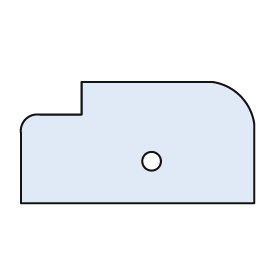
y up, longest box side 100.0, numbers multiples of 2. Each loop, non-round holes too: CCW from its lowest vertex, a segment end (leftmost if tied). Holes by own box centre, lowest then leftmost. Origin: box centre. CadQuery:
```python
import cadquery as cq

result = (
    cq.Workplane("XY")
    .moveTo(-50.0, -26.0)
    .lineTo(50.0, -26.0)
    .lineTo(50.0, 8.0)
    .threePointArc((44.0, 20.0), (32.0, 26.0))
    .lineTo(-24.0, 26.0)
    .lineTo(-24.0, 12.0)
    .lineTo(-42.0, 12.0)
    .threePointArc((-48.0, 10.0), (-50.0, 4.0))
    .close()
    .moveTo(6.0, -8.0)
    .circle(4.0)
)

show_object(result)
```